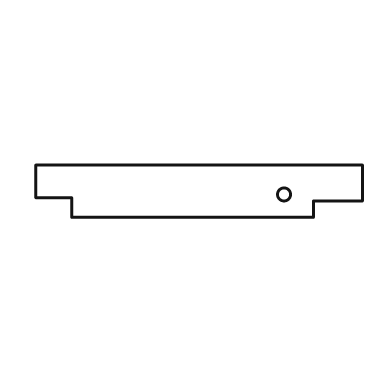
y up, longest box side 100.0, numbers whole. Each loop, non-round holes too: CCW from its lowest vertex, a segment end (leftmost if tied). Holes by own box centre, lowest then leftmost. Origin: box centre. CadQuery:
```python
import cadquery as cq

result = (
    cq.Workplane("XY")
    .moveTo(-39.0, -8.0)
    .lineTo(35.0, -8.0)
    .lineTo(35.0, -3.0)
    .lineTo(50.0, -3.0)
    .lineTo(50.0, 8.0)
    .lineTo(-50.0, 8.0)
    .lineTo(-50.0, -2.0)
    .lineTo(-39.0, -2.0)
    .close()
    .moveTo(26.0, -1.0)
    .circle(2.0)
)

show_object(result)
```